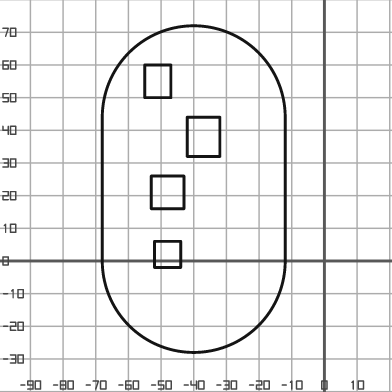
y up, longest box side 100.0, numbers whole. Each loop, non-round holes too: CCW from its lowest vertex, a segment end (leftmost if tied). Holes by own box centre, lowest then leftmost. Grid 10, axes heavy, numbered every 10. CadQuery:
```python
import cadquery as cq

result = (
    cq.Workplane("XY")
    .moveTo(-68.0, 0.0)
    .threePointArc((-40.0, -28.0), (-12.0, 0.0))
    .lineTo(-12.0, 44.0)
    .threePointArc((-40.0, 72.0), (-68.0, 44.0))
    .close()
    .moveTo(-52.0, -2.0)
    .lineTo(-44.0, -2.0)
    .lineTo(-44.0, 6.0)
    .lineTo(-52.0, 6.0)
    .close()
    .moveTo(-53.0, 16.0)
    .lineTo(-43.0, 16.0)
    .lineTo(-43.0, 26.0)
    .lineTo(-53.0, 26.0)
    .close()
    .moveTo(-42.0, 32.0)
    .lineTo(-32.0, 32.0)
    .lineTo(-32.0, 44.0)
    .lineTo(-42.0, 44.0)
    .close()
    .moveTo(-55.0, 50.0)
    .lineTo(-47.0, 50.0)
    .lineTo(-47.0, 60.0)
    .lineTo(-55.0, 60.0)
    .close()
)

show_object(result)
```